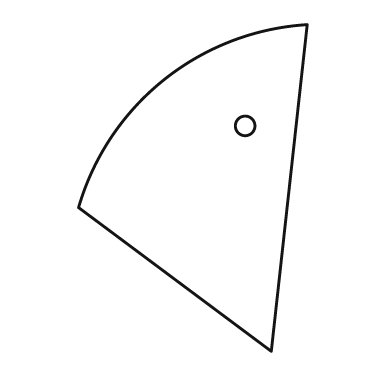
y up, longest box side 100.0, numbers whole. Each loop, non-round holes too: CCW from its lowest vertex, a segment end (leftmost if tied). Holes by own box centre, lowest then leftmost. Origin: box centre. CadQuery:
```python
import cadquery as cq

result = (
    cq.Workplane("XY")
    .moveTo(24.0, -50.0)
    .lineTo(35.0, 50.0)
    .threePointArc((-9.0, 33.0), (-35.0, -6.0))
    .close()
    .moveTo(16.0, 19.0)
    .circle(3.0)
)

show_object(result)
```